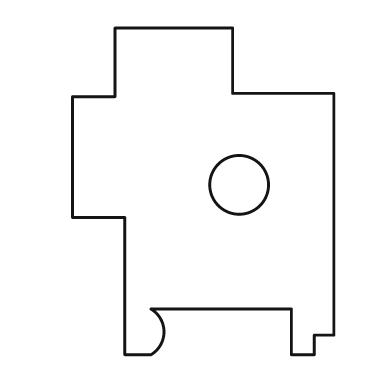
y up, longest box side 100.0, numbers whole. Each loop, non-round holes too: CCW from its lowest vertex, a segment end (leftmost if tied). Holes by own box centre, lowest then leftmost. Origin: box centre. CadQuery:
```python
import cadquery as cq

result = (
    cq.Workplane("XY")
    .moveTo(-24.0, -50.0)
    .lineTo(-16.0, -50.0)
    .threePointArc((-12.0, -43.0), (-16.0, -36.0))
    .lineTo(27.0, -36.0)
    .lineTo(27.0, -50.0)
    .lineTo(34.0, -50.0)
    .lineTo(34.0, -44.0)
    .lineTo(40.0, -44.0)
    .lineTo(40.0, 30.0)
    .lineTo(9.0, 30.0)
    .lineTo(9.0, 50.0)
    .lineTo(-27.0, 50.0)
    .lineTo(-27.0, 29.0)
    .lineTo(-40.0, 29.0)
    .lineTo(-40.0, -8.0)
    .lineTo(-24.0, -8.0)
    .close()
    .moveTo(11.0, 2.0)
    .circle(9.0)
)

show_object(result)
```